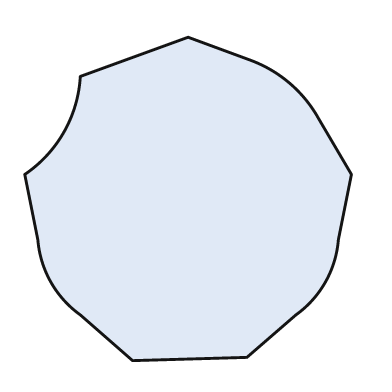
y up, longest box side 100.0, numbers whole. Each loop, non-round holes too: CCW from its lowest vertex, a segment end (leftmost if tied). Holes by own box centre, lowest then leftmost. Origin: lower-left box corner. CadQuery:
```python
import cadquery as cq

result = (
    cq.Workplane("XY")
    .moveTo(33.0, 0.0)
    .lineTo(68.0, 1.0)
    .lineTo(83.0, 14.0)
    .threePointArc((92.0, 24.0), (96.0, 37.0))
    .lineTo(100.0, 57.0)
    .lineTo(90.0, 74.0)
    .threePointArc((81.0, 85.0), (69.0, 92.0))
    .lineTo(50.0, 99.0)
    .lineTo(17.0, 87.0)
    .threePointArc((12.0, 70.0), (0.0, 57.0))
    .lineTo(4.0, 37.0)
    .threePointArc((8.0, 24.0), (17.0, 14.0))
    .close()
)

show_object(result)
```